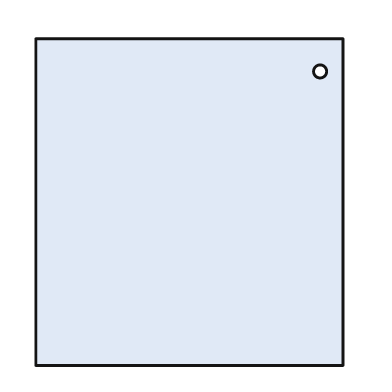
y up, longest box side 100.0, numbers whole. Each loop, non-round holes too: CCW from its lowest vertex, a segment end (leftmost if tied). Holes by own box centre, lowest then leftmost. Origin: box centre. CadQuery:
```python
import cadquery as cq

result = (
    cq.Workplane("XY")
    .moveTo(-47.0, -50.0)
    .lineTo(47.0, -50.0)
    .lineTo(47.0, 50.0)
    .lineTo(-47.0, 50.0)
    .close()
    .moveTo(40.0, 40.0)
    .circle(2.0)
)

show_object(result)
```